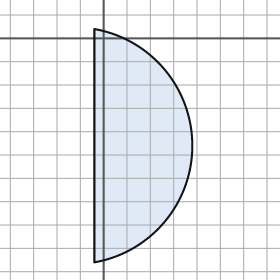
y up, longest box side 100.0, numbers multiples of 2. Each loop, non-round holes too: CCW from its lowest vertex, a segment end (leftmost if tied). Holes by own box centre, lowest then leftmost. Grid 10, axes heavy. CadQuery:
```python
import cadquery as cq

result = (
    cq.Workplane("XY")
    .moveTo(-4.0, -96.0)
    .threePointArc((38.0, -46.0), (-4.0, 4.0))
    .close()
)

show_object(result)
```